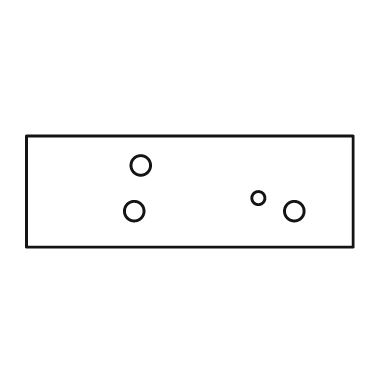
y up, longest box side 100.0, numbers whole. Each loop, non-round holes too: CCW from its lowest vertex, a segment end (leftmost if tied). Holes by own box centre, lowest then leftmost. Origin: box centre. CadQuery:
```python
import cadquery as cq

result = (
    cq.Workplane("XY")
    .moveTo(-50.0, -17.0)
    .lineTo(50.0, -17.0)
    .lineTo(50.0, 17.0)
    .lineTo(-50.0, 17.0)
    .close()
    .moveTo(-17.0, -6.0)
    .circle(3.0)
    .moveTo(32.0, -6.0)
    .circle(3.0)
    .moveTo(21.0, -2.0)
    .circle(2.0)
    .moveTo(-15.0, 8.0)
    .circle(3.0)
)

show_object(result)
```